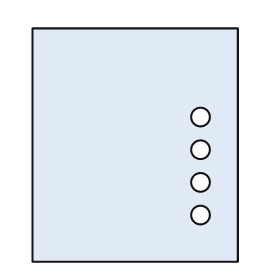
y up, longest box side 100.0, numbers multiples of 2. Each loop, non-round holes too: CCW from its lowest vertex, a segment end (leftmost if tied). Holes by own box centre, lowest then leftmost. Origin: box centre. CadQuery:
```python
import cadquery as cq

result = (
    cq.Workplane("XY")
    .moveTo(-44.0, -50.0)
    .lineTo(44.0, -50.0)
    .lineTo(44.0, 50.0)
    .lineTo(-44.0, 50.0)
    .close()
    .moveTo(28.0, -30.0)
    .circle(4.0)
    .moveTo(28.0, -16.0)
    .circle(4.0)
    .moveTo(28.0, -2.0)
    .circle(4.0)
    .moveTo(28.0, 12.0)
    .circle(4.0)
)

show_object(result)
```